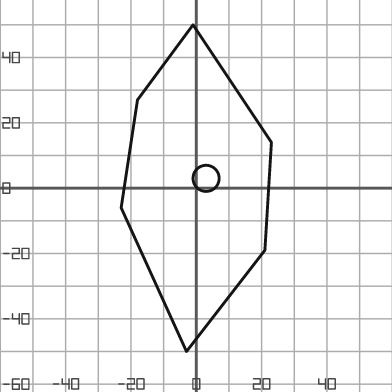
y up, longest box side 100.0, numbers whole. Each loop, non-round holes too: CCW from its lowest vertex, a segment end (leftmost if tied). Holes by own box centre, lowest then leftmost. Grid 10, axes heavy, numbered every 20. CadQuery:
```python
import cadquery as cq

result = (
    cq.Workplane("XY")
    .moveTo(-3.0, -50.0)
    .lineTo(21.0, -19.0)
    .lineTo(23.0, 14.0)
    .lineTo(-1.0, 50.0)
    .lineTo(-18.0, 27.0)
    .lineTo(-23.0, -6.0)
    .close()
    .moveTo(3.0, 3.0)
    .circle(4.0)
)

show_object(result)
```